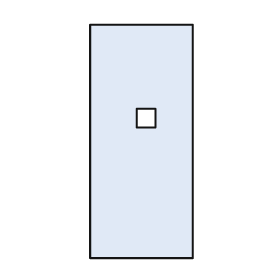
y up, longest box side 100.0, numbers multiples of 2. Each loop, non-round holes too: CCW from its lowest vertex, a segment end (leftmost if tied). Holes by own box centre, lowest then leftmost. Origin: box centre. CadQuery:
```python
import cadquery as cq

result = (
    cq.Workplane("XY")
    .moveTo(-22.0, -50.0)
    .lineTo(22.0, -50.0)
    .lineTo(22.0, 50.0)
    .lineTo(-22.0, 50.0)
    .close()
    .moveTo(-2.0, 6.0)
    .lineTo(6.0, 6.0)
    .lineTo(6.0, 14.0)
    .lineTo(-2.0, 14.0)
    .close()
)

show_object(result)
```